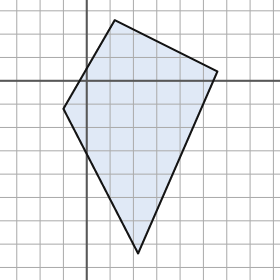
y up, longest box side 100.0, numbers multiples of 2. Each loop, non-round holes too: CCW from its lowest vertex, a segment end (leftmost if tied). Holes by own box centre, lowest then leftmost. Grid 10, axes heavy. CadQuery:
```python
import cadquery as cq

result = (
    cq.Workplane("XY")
    .moveTo(22.0, -74.0)
    .lineTo(56.0, 4.0)
    .lineTo(12.0, 26.0)
    .lineTo(-10.0, -12.0)
    .close()
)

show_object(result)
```